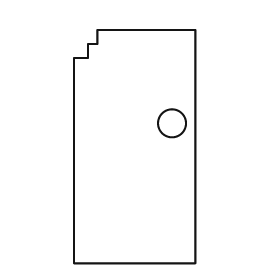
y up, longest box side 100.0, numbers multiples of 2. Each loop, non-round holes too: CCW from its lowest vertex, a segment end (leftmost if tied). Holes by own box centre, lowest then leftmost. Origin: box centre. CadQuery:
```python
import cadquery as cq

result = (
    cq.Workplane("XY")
    .moveTo(-26.0, -50.0)
    .lineTo(26.0, -50.0)
    .lineTo(26.0, 50.0)
    .lineTo(-16.0, 50.0)
    .lineTo(-16.0, 44.0)
    .lineTo(-20.0, 44.0)
    .lineTo(-20.0, 38.0)
    .lineTo(-26.0, 38.0)
    .close()
    .moveTo(16.0, 10.0)
    .circle(6.0)
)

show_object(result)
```